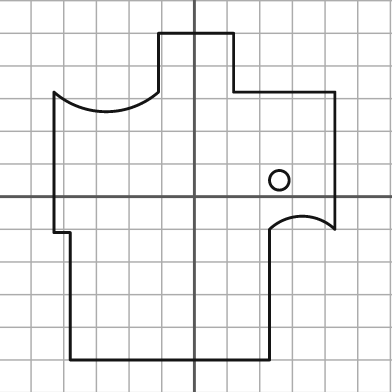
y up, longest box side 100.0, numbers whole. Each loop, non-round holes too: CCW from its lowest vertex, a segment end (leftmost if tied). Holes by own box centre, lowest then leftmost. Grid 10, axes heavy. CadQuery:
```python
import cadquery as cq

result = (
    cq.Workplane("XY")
    .moveTo(-38.0, -50.0)
    .lineTo(23.0, -50.0)
    .lineTo(23.0, -10.0)
    .threePointArc((33.0, -6.0), (43.0, -10.0))
    .lineTo(43.0, 32.0)
    .lineTo(12.0, 32.0)
    .lineTo(12.0, 50.0)
    .lineTo(-11.0, 50.0)
    .lineTo(-11.0, 32.0)
    .threePointArc((-27.0, 26.0), (-43.0, 32.0))
    .lineTo(-43.0, -11.0)
    .lineTo(-38.0, -11.0)
    .close()
    .moveTo(26.0, 5.0)
    .circle(3.0)
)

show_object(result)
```